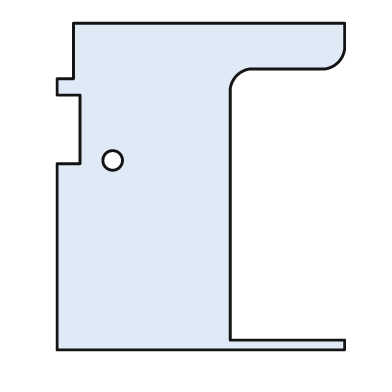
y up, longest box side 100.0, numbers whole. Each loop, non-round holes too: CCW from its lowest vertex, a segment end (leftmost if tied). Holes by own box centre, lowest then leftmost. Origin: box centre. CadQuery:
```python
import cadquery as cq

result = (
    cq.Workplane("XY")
    .moveTo(-44.0, -50.0)
    .lineTo(44.0, -50.0)
    .lineTo(44.0, -47.0)
    .lineTo(9.0, -47.0)
    .lineTo(9.0, 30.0)
    .threePointArc((11.0, 34.0), (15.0, 36.0))
    .lineTo(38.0, 36.0)
    .threePointArc((42.0, 38.0), (44.0, 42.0))
    .lineTo(44.0, 50.0)
    .lineTo(-39.0, 50.0)
    .lineTo(-39.0, 33.0)
    .lineTo(-44.0, 33.0)
    .lineTo(-44.0, 28.0)
    .lineTo(-37.0, 28.0)
    .lineTo(-37.0, 7.0)
    .lineTo(-44.0, 7.0)
    .close()
    .moveTo(-27.0, 8.0)
    .circle(3.0)
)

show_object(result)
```